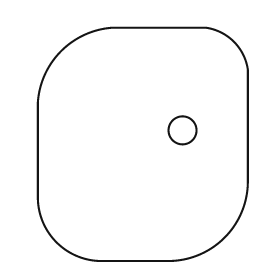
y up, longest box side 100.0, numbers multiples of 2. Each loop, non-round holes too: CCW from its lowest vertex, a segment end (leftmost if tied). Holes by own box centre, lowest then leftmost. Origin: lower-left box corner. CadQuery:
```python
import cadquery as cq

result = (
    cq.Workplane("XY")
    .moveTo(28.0, 0.0)
    .lineTo(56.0, 0.0)
    .threePointArc((80.0, 10.0), (90.0, 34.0))
    .lineTo(90.0, 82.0)
    .threePointArc((84.0, 94.0), (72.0, 100.0))
    .lineTo(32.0, 100.0)
    .threePointArc((10.0, 90.0), (0.0, 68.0))
    .lineTo(0.0, 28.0)
    .threePointArc((8.0, 8.0), (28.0, 0.0))
    .close()
    .moveTo(62.0, 56.0)
    .circle(6.0)
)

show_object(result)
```